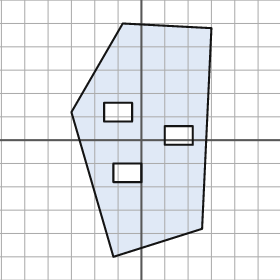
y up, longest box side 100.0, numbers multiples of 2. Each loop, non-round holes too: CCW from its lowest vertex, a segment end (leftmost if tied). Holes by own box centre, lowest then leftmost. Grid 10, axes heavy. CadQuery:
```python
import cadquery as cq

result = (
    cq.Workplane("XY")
    .moveTo(-12.0, -50.0)
    .lineTo(26.0, -38.0)
    .lineTo(30.0, 48.0)
    .lineTo(-8.0, 50.0)
    .lineTo(-30.0, 12.0)
    .close()
    .moveTo(-12.0, -18.0)
    .lineTo(0.0, -18.0)
    .lineTo(0.0, -10.0)
    .lineTo(-12.0, -10.0)
    .close()
    .moveTo(10.0, -2.0)
    .lineTo(22.0, -2.0)
    .lineTo(22.0, 6.0)
    .lineTo(10.0, 6.0)
    .close()
    .moveTo(-16.0, 8.0)
    .lineTo(-4.0, 8.0)
    .lineTo(-4.0, 16.0)
    .lineTo(-16.0, 16.0)
    .close()
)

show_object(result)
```